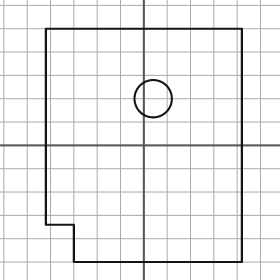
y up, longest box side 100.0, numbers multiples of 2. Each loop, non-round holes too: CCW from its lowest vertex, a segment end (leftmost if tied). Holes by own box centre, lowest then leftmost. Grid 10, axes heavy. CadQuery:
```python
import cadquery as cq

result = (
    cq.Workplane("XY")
    .moveTo(-30.0, -50.0)
    .lineTo(42.0, -50.0)
    .lineTo(42.0, 50.0)
    .lineTo(-42.0, 50.0)
    .lineTo(-42.0, -34.0)
    .lineTo(-30.0, -34.0)
    .close()
    .moveTo(4.0, 20.0)
    .circle(8.0)
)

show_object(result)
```